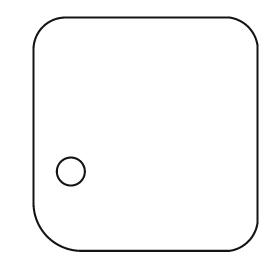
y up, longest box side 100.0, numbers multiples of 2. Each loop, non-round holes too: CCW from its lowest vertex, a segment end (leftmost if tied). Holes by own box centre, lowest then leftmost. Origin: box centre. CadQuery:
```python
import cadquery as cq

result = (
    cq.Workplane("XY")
    .moveTo(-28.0, -50.0)
    .lineTo(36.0, -50.0)
    .threePointArc((44.0, -46.0), (48.0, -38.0))
    .lineTo(48.0, 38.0)
    .threePointArc((44.0, 46.0), (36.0, 50.0))
    .lineTo(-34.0, 50.0)
    .threePointArc((-44.0, 46.0), (-48.0, 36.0))
    .lineTo(-48.0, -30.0)
    .threePointArc((-42.0, -44.0), (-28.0, -50.0))
    .close()
    .moveTo(-32.0, -16.0)
    .circle(6.0)
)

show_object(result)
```